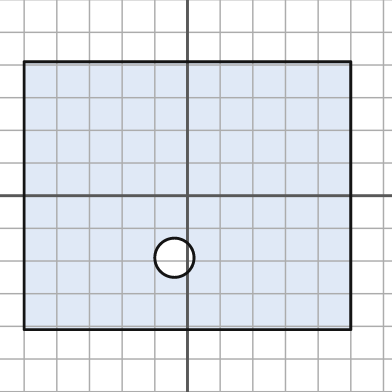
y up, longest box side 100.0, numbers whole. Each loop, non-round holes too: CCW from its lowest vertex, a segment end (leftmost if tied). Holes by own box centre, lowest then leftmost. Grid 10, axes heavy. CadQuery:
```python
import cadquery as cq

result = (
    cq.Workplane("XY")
    .moveTo(-50.0, -41.0)
    .lineTo(50.0, -41.0)
    .lineTo(50.0, 41.0)
    .lineTo(-50.0, 41.0)
    .close()
    .moveTo(-4.0, -19.0)
    .circle(6.0)
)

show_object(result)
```